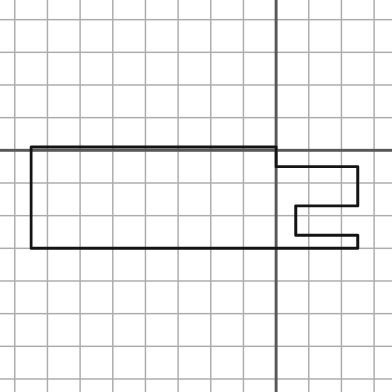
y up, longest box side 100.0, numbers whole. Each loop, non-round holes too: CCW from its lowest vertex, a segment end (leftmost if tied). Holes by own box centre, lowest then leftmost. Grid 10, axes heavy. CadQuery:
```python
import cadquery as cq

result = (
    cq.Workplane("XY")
    .moveTo(-75.0, -30.0)
    .lineTo(25.0, -30.0)
    .lineTo(25.0, -26.0)
    .lineTo(6.0, -26.0)
    .lineTo(6.0, -17.0)
    .lineTo(25.0, -17.0)
    .lineTo(25.0, -5.0)
    .lineTo(0.0, -5.0)
    .lineTo(0.0, 1.0)
    .lineTo(-75.0, 1.0)
    .close()
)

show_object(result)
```